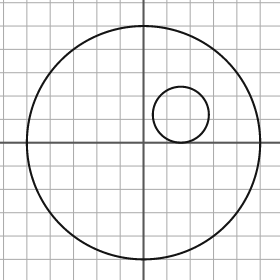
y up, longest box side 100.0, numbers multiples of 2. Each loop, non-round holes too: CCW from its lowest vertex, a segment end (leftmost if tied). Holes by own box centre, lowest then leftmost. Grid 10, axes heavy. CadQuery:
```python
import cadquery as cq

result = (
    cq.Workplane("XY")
    .moveTo(0.0, 0.0)
    .circle(50.0)
    .moveTo(16.0, 12.0)
    .circle(12.0)
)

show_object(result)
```